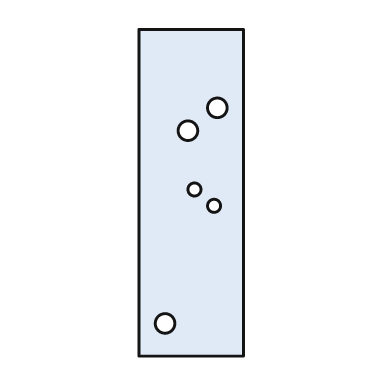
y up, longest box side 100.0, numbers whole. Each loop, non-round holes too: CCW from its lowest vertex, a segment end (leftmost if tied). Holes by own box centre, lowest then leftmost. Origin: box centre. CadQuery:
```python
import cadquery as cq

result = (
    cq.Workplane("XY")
    .moveTo(-16.0, -50.0)
    .lineTo(16.0, -50.0)
    .lineTo(16.0, 50.0)
    .lineTo(-16.0, 50.0)
    .close()
    .moveTo(-8.0, -40.0)
    .circle(3.0)
    .moveTo(7.0, -4.0)
    .circle(2.0)
    .moveTo(1.0, 1.0)
    .circle(2.0)
    .moveTo(-1.0, 19.0)
    .circle(3.0)
    .moveTo(8.0, 26.0)
    .circle(3.0)
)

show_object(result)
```